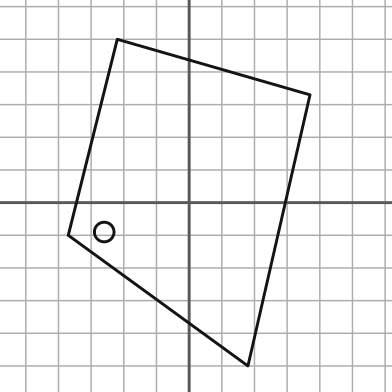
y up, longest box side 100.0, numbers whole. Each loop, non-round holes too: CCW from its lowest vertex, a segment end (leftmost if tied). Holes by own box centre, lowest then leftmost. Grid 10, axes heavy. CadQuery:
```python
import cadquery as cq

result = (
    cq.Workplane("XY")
    .moveTo(18.0, -50.0)
    .lineTo(37.0, 33.0)
    .lineTo(-22.0, 50.0)
    .lineTo(-37.0, -10.0)
    .close()
    .moveTo(-26.0, -9.0)
    .circle(3.0)
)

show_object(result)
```